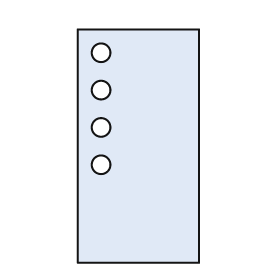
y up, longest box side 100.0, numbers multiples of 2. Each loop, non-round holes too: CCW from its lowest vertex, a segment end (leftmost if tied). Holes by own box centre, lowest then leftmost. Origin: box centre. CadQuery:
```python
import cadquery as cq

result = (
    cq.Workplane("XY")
    .moveTo(-26.0, -50.0)
    .lineTo(26.0, -50.0)
    .lineTo(26.0, 50.0)
    .lineTo(-26.0, 50.0)
    .close()
    .moveTo(-16.0, -8.0)
    .circle(4.0)
    .moveTo(-16.0, 8.0)
    .circle(4.0)
    .moveTo(-16.0, 24.0)
    .circle(4.0)
    .moveTo(-16.0, 40.0)
    .circle(4.0)
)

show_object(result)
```